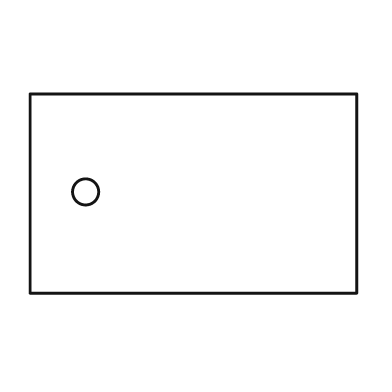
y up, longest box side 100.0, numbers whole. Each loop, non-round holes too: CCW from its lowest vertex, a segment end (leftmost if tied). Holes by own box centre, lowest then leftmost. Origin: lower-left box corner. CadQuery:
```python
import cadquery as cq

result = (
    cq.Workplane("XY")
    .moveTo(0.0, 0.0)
    .lineTo(100.0, 0.0)
    .lineTo(100.0, 61.0)
    .lineTo(0.0, 61.0)
    .close()
    .moveTo(17.0, 31.0)
    .circle(4.0)
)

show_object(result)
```